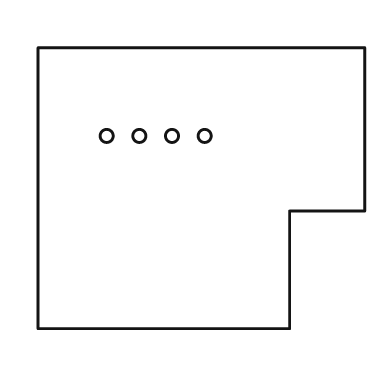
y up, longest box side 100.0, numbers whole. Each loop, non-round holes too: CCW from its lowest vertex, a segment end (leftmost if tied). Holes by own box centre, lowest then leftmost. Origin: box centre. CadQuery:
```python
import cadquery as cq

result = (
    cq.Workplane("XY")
    .moveTo(-50.0, -43.0)
    .lineTo(27.0, -43.0)
    .lineTo(27.0, -7.0)
    .lineTo(50.0, -7.0)
    .lineTo(50.0, 43.0)
    .lineTo(-50.0, 43.0)
    .close()
    .moveTo(-29.0, 16.0)
    .circle(2.0)
    .moveTo(-19.0, 16.0)
    .circle(2.0)
    .moveTo(-9.0, 16.0)
    .circle(2.0)
    .moveTo(1.0, 16.0)
    .circle(2.0)
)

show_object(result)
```